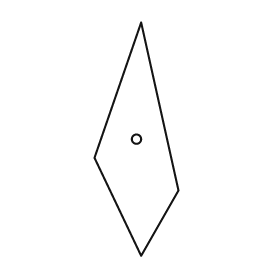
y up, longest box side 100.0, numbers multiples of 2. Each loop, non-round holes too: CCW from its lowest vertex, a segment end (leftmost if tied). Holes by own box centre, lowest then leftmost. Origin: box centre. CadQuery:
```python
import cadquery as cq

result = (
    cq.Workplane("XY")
    .moveTo(2.0, -50.0)
    .lineTo(18.0, -22.0)
    .lineTo(2.0, 50.0)
    .lineTo(-18.0, -8.0)
    .close()
    .moveTo(0.0, 0.0)
    .circle(2.0)
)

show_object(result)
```